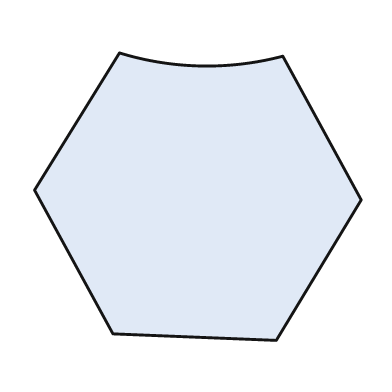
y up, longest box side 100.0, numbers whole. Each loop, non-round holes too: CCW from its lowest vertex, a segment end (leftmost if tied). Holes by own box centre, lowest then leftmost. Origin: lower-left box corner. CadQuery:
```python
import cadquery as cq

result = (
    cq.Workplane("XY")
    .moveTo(74.0, 0.0)
    .lineTo(100.0, 43.0)
    .lineTo(76.0, 87.0)
    .threePointArc((51.0, 84.0), (26.0, 88.0))
    .lineTo(0.0, 46.0)
    .lineTo(24.0, 2.0)
    .close()
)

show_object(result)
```